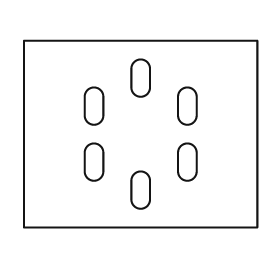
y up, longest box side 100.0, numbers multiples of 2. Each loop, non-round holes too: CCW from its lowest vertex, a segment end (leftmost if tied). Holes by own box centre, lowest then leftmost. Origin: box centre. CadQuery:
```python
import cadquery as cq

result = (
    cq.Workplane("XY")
    .moveTo(-50.0, -40.0)
    .lineTo(50.0, -40.0)
    .lineTo(50.0, 40.0)
    .lineTo(-50.0, 40.0)
    .close()
    .moveTo(-4.0, -28.0)
    .threePointArc((0.0, -32.0), (4.0, -28.0))
    .lineTo(4.0, -20.0)
    .threePointArc((0.0, -16.0), (-4.0, -20.0))
    .close()
    .moveTo(-24.0, -16.0)
    .threePointArc((-20.0, -20.0), (-16.0, -16.0))
    .lineTo(-16.0, -8.0)
    .threePointArc((-20.0, -4.0), (-24.0, -8.0))
    .close()
    .moveTo(16.0, -16.0)
    .threePointArc((20.0, -20.0), (24.0, -16.0))
    .lineTo(24.0, -8.0)
    .threePointArc((20.0, -4.0), (16.0, -8.0))
    .close()
    .moveTo(-24.0, 8.0)
    .threePointArc((-20.0, 4.0), (-16.0, 8.0))
    .lineTo(-16.0, 16.0)
    .threePointArc((-20.0, 20.0), (-24.0, 16.0))
    .close()
    .moveTo(16.0, 8.0)
    .threePointArc((20.0, 4.0), (24.0, 8.0))
    .lineTo(24.0, 16.0)
    .threePointArc((20.0, 20.0), (16.0, 16.0))
    .close()
    .moveTo(-4.0, 20.0)
    .threePointArc((0.0, 16.0), (4.0, 20.0))
    .lineTo(4.0, 28.0)
    .threePointArc((0.0, 32.0), (-4.0, 28.0))
    .close()
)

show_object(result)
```